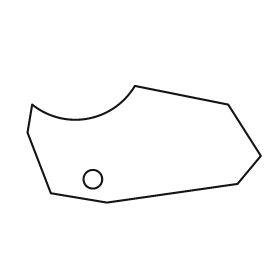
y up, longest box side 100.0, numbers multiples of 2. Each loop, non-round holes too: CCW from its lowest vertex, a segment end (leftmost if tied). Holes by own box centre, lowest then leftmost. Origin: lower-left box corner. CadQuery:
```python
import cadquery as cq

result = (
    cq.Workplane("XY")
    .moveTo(34.0, 0.0)
    .lineTo(90.0, 8.0)
    .lineTo(100.0, 20.0)
    .lineTo(86.0, 42.0)
    .lineTo(46.0, 50.0)
    .threePointArc((26.0, 36.0), (2.0, 42.0))
    .lineTo(0.0, 30.0)
    .lineTo(10.0, 4.0)
    .close()
    .moveTo(28.0, 10.0)
    .circle(4.0)
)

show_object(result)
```